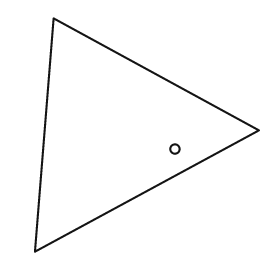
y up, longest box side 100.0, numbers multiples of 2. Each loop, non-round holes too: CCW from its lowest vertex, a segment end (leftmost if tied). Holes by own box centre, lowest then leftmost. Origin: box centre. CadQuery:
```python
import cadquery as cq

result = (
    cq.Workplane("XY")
    .moveTo(-48.0, -50.0)
    .lineTo(48.0, 2.0)
    .lineTo(-40.0, 50.0)
    .close()
    .moveTo(12.0, -6.0)
    .circle(2.0)
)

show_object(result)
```